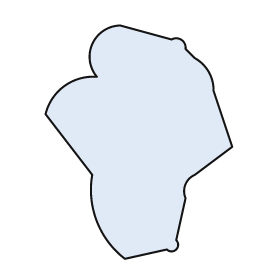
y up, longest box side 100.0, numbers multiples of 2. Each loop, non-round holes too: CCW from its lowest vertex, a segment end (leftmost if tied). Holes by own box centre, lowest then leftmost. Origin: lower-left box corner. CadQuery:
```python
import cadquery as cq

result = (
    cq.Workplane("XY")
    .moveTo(34.0, 0.0)
    .lineTo(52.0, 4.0)
    .threePointArc((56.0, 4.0), (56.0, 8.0))
    .lineTo(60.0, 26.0)
    .threePointArc((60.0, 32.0), (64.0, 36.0))
    .lineTo(80.0, 48.0)
    .lineTo(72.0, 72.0)
    .threePointArc((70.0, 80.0), (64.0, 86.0))
    .lineTo(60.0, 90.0)
    .threePointArc((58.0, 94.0), (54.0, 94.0))
    .lineTo(32.0, 100.0)
    .threePointArc((20.0, 92.0), (22.0, 78.0))
    .threePointArc((8.0, 74.0), (0.0, 62.0))
    .lineTo(20.0, 36.0)
    .threePointArc((22.0, 16.0), (34.0, 0.0))
    .close()
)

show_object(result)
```